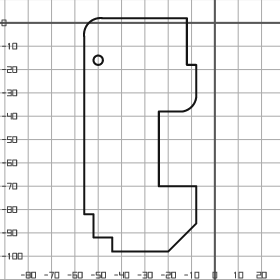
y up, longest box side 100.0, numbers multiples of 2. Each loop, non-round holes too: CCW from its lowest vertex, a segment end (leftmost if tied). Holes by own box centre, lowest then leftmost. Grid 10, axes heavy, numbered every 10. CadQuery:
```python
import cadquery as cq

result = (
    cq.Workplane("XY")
    .moveTo(-44.0, -98.0)
    .lineTo(-20.0, -98.0)
    .lineTo(-8.0, -86.0)
    .lineTo(-8.0, -70.0)
    .lineTo(-24.0, -70.0)
    .lineTo(-24.0, -38.0)
    .lineTo(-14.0, -38.0)
    .threePointArc((-10.0, -36.0), (-8.0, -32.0))
    .lineTo(-8.0, -18.0)
    .lineTo(-12.0, -18.0)
    .lineTo(-12.0, 2.0)
    .lineTo(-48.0, 2.0)
    .threePointArc((-54.0, 0.0), (-56.0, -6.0))
    .lineTo(-56.0, -82.0)
    .lineTo(-52.0, -82.0)
    .lineTo(-52.0, -92.0)
    .lineTo(-44.0, -92.0)
    .close()
    .moveTo(-50.0, -16.0)
    .circle(2.0)
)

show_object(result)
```